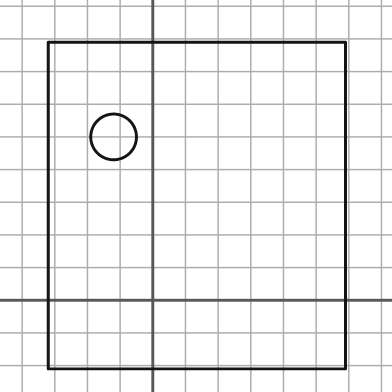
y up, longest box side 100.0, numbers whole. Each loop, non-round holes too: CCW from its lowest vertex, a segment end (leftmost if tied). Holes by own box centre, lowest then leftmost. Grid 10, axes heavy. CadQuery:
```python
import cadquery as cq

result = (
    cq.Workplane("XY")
    .moveTo(-32.0, -21.0)
    .lineTo(59.0, -21.0)
    .lineTo(59.0, 79.0)
    .lineTo(-32.0, 79.0)
    .close()
    .moveTo(-12.0, 50.0)
    .circle(7.0)
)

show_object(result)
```